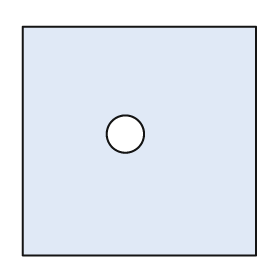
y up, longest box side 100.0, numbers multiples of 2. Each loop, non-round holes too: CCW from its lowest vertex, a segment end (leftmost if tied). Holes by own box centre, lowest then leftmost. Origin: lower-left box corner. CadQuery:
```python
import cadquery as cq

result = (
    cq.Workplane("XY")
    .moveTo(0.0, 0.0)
    .lineTo(100.0, 0.0)
    .lineTo(100.0, 98.0)
    .lineTo(0.0, 98.0)
    .close()
    .moveTo(44.0, 52.0)
    .circle(8.0)
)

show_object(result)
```